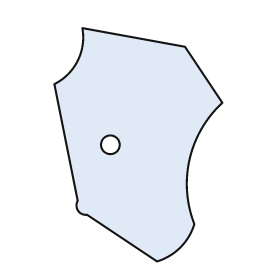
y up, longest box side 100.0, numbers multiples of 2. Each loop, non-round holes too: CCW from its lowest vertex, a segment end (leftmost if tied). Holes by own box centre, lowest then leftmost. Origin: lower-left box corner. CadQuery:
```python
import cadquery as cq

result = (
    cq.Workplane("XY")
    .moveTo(44.0, 0.0)
    .threePointArc((54.0, 6.0), (60.0, 16.0))
    .threePointArc((58.0, 44.0), (72.0, 68.0))
    .lineTo(56.0, 92.0)
    .lineTo(12.0, 100.0)
    .threePointArc((10.0, 86.0), (0.0, 76.0))
    .lineTo(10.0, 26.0)
    .threePointArc((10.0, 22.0), (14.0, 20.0))
    .close()
    .moveTo(24.0, 50.0)
    .circle(4.0)
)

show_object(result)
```